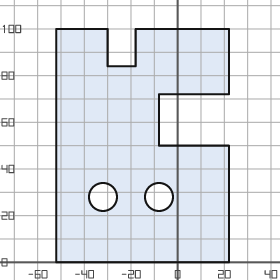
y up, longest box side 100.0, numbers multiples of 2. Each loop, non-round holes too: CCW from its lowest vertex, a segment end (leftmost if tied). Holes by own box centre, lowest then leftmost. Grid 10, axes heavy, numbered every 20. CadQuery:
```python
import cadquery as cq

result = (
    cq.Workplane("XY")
    .moveTo(-52.0, 0.0)
    .lineTo(22.0, 0.0)
    .lineTo(22.0, 50.0)
    .lineTo(-8.0, 50.0)
    .lineTo(-8.0, 72.0)
    .lineTo(22.0, 72.0)
    .lineTo(22.0, 100.0)
    .lineTo(-18.0, 100.0)
    .lineTo(-18.0, 84.0)
    .lineTo(-30.0, 84.0)
    .lineTo(-30.0, 100.0)
    .lineTo(-52.0, 100.0)
    .close()
    .moveTo(-32.0, 28.0)
    .circle(6.0)
    .moveTo(-8.0, 28.0)
    .circle(6.0)
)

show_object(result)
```